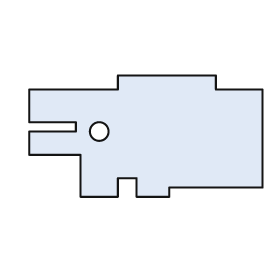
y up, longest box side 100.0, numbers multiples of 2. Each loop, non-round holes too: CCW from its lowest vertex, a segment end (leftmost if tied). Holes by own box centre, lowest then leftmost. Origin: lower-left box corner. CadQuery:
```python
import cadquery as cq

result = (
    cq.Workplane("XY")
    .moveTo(22.0, 0.0)
    .lineTo(38.0, 0.0)
    .lineTo(38.0, 8.0)
    .lineTo(46.0, 8.0)
    .lineTo(46.0, 0.0)
    .lineTo(60.0, 0.0)
    .lineTo(60.0, 4.0)
    .lineTo(100.0, 4.0)
    .lineTo(100.0, 46.0)
    .lineTo(80.0, 46.0)
    .lineTo(80.0, 52.0)
    .lineTo(38.0, 52.0)
    .lineTo(38.0, 46.0)
    .lineTo(0.0, 46.0)
    .lineTo(0.0, 32.0)
    .lineTo(20.0, 32.0)
    .lineTo(20.0, 28.0)
    .lineTo(0.0, 28.0)
    .lineTo(0.0, 18.0)
    .lineTo(22.0, 18.0)
    .close()
    .moveTo(30.0, 28.0)
    .circle(4.0)
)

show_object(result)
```